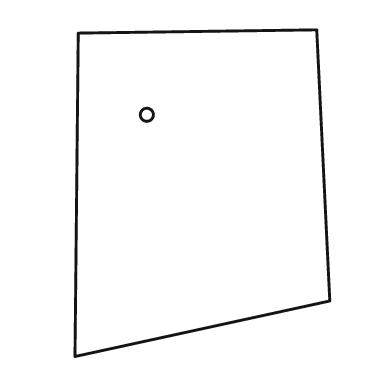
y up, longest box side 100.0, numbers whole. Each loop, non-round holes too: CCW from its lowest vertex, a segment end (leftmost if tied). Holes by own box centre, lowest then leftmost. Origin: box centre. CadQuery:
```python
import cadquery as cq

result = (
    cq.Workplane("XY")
    .moveTo(-39.0, -50.0)
    .lineTo(39.0, -33.0)
    .lineTo(35.0, 50.0)
    .lineTo(-38.0, 49.0)
    .close()
    .moveTo(-17.0, 24.0)
    .circle(2.0)
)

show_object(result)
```